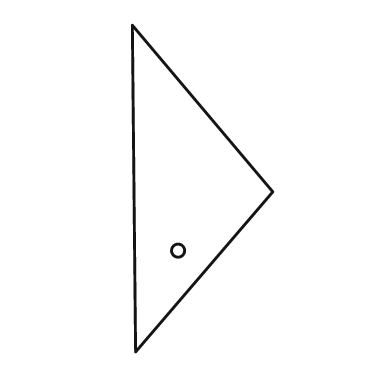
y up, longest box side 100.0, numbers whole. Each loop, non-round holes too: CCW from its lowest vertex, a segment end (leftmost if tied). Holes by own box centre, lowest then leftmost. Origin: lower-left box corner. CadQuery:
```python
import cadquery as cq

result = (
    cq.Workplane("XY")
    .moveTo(1.0, 0.0)
    .lineTo(43.0, 49.0)
    .lineTo(0.0, 100.0)
    .close()
    .moveTo(14.0, 31.0)
    .circle(2.0)
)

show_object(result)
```